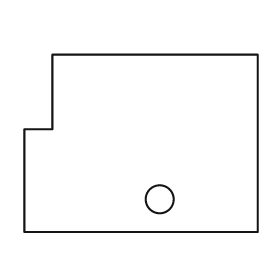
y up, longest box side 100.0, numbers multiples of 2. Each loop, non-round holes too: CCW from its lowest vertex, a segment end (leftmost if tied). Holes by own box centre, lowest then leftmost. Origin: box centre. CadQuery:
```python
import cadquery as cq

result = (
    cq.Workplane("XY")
    .moveTo(-50.0, -38.0)
    .lineTo(50.0, -38.0)
    .lineTo(50.0, 38.0)
    .lineTo(-38.0, 38.0)
    .lineTo(-38.0, 6.0)
    .lineTo(-50.0, 6.0)
    .close()
    .moveTo(8.0, -24.0)
    .circle(6.0)
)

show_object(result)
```